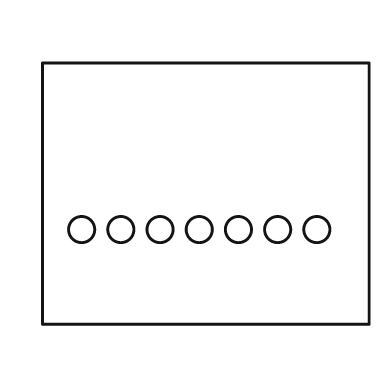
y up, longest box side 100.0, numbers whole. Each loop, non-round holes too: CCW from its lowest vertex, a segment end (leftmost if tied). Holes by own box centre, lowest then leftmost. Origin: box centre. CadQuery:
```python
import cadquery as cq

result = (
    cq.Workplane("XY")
    .moveTo(-50.0, -40.0)
    .lineTo(50.0, -40.0)
    .lineTo(50.0, 40.0)
    .lineTo(-50.0, 40.0)
    .close()
    .moveTo(-38.0, -11.0)
    .circle(4.0)
    .moveTo(-26.0, -11.0)
    .circle(4.0)
    .moveTo(-14.0, -11.0)
    .circle(4.0)
    .moveTo(-2.0, -11.0)
    .circle(4.0)
    .moveTo(10.0, -11.0)
    .circle(4.0)
    .moveTo(22.0, -11.0)
    .circle(4.0)
    .moveTo(34.0, -11.0)
    .circle(4.0)
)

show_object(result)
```